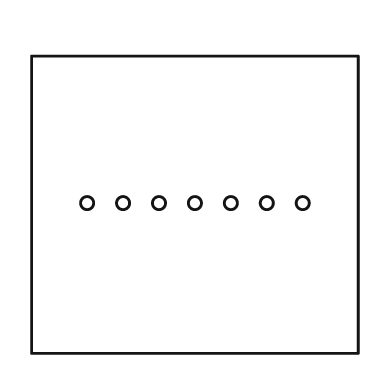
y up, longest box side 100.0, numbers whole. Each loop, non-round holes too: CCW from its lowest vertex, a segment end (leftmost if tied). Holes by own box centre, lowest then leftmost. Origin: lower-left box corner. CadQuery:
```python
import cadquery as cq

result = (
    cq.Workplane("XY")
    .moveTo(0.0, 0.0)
    .lineTo(100.0, 0.0)
    .lineTo(100.0, 91.0)
    .lineTo(0.0, 91.0)
    .close()
    .moveTo(17.0, 46.0)
    .circle(2.0)
    .moveTo(28.0, 46.0)
    .circle(2.0)
    .moveTo(39.0, 46.0)
    .circle(2.0)
    .moveTo(50.0, 46.0)
    .circle(2.0)
    .moveTo(61.0, 46.0)
    .circle(2.0)
    .moveTo(72.0, 46.0)
    .circle(2.0)
    .moveTo(83.0, 46.0)
    .circle(2.0)
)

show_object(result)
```